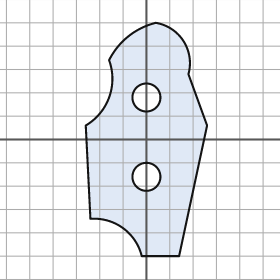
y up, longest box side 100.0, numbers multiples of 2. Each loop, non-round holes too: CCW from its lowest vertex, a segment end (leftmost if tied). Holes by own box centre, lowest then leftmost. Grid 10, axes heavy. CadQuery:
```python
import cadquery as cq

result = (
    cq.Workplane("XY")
    .moveTo(-2.0, -50.0)
    .lineTo(14.0, -50.0)
    .lineTo(26.0, 6.0)
    .lineTo(18.0, 28.0)
    .threePointArc((16.0, 42.0), (4.0, 50.0))
    .threePointArc((-8.0, 44.0), (-16.0, 34.0))
    .threePointArc((-16.0, 18.0), (-26.0, 6.0))
    .lineTo(-24.0, -34.0)
    .threePointArc((-10.0, -38.0), (-2.0, -50.0))
    .close()
    .moveTo(0.0, -16.0)
    .circle(6.0)
    .moveTo(0.0, 18.0)
    .circle(6.0)
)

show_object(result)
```